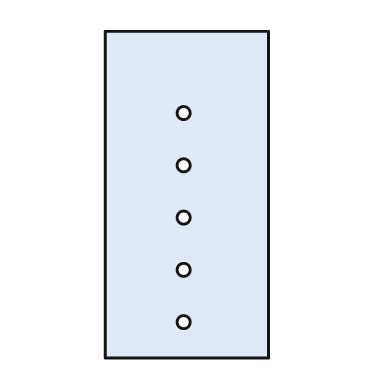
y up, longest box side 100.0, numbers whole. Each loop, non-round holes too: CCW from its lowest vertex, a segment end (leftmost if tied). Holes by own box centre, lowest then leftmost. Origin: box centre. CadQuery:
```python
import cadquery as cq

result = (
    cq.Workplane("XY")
    .moveTo(-25.0, -50.0)
    .lineTo(25.0, -50.0)
    .lineTo(25.0, 50.0)
    .lineTo(-25.0, 50.0)
    .close()
    .moveTo(-1.0, -39.0)
    .circle(2.0)
    .moveTo(-1.0, -23.0)
    .circle(2.0)
    .moveTo(-1.0, -7.0)
    .circle(2.0)
    .moveTo(-1.0, 9.0)
    .circle(2.0)
    .moveTo(-1.0, 25.0)
    .circle(2.0)
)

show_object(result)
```